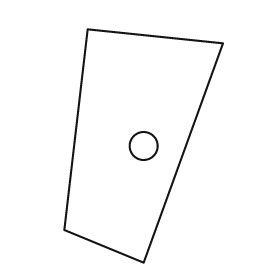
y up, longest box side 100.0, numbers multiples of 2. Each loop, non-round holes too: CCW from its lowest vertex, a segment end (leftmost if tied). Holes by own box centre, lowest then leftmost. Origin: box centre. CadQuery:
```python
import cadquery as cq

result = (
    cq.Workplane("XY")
    .moveTo(0.0, -50.0)
    .lineTo(34.0, 44.0)
    .lineTo(-24.0, 50.0)
    .lineTo(-34.0, -36.0)
    .close()
    .moveTo(0.0, 0.0)
    .circle(6.0)
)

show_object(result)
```